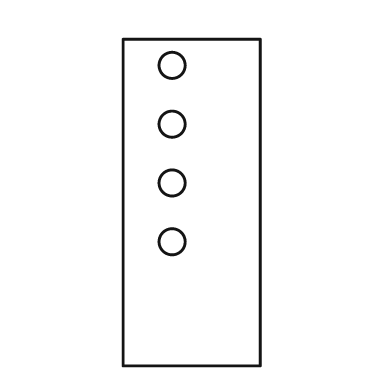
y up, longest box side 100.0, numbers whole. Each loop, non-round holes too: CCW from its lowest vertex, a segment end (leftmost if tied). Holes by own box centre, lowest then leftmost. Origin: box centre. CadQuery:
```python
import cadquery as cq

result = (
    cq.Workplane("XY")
    .moveTo(-21.0, -50.0)
    .lineTo(21.0, -50.0)
    .lineTo(21.0, 50.0)
    .lineTo(-21.0, 50.0)
    .close()
    .moveTo(-6.0, -12.0)
    .circle(4.0)
    .moveTo(-6.0, 6.0)
    .circle(4.0)
    .moveTo(-6.0, 24.0)
    .circle(4.0)
    .moveTo(-6.0, 42.0)
    .circle(4.0)
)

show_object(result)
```